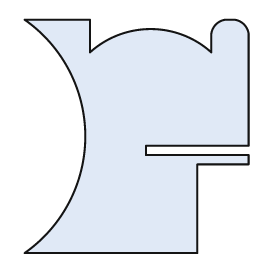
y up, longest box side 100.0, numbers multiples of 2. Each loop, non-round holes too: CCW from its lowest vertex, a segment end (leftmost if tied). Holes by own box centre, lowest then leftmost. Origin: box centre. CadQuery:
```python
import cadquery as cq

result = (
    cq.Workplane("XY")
    .moveTo(-48.0, -50.0)
    .lineTo(26.0, -50.0)
    .lineTo(26.0, -12.0)
    .lineTo(48.0, -12.0)
    .lineTo(48.0, -8.0)
    .lineTo(4.0, -8.0)
    .lineTo(4.0, -4.0)
    .lineTo(48.0, -4.0)
    .lineTo(48.0, 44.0)
    .threePointArc((46.0, 48.0), (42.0, 50.0))
    .lineTo(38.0, 50.0)
    .threePointArc((34.0, 48.0), (32.0, 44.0))
    .lineTo(32.0, 36.0)
    .threePointArc((6.0, 46.0), (-20.0, 36.0))
    .lineTo(-20.0, 50.0)
    .lineTo(-48.0, 50.0)
    .threePointArc((-22.0, 0.0), (-48.0, -50.0))
    .close()
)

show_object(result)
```